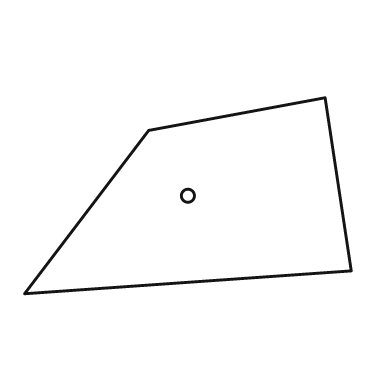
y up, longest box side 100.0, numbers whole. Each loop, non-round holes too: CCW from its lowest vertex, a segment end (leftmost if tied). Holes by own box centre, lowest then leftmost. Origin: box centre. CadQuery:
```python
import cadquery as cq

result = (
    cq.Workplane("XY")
    .moveTo(-50.0, -30.0)
    .lineTo(50.0, -23.0)
    .lineTo(42.0, 30.0)
    .lineTo(-12.0, 20.0)
    .close()
    .moveTo(0.0, 0.0)
    .circle(2.0)
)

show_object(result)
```